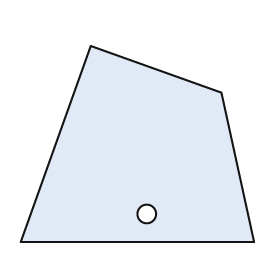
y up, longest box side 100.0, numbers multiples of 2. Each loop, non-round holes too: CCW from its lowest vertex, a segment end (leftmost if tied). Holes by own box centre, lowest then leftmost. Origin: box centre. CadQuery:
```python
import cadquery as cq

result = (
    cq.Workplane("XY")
    .moveTo(-50.0, -42.0)
    .lineTo(50.0, -42.0)
    .lineTo(36.0, 22.0)
    .lineTo(-20.0, 42.0)
    .close()
    .moveTo(4.0, -30.0)
    .circle(4.0)
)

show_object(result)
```